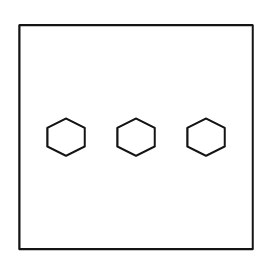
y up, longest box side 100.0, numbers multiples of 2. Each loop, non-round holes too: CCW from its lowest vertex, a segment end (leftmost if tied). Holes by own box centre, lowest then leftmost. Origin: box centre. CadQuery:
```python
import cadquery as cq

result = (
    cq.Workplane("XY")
    .moveTo(-50.0, -48.0)
    .lineTo(50.0, -48.0)
    .lineTo(50.0, 48.0)
    .lineTo(-50.0, 48.0)
    .close()
    .moveTo(-30.0, -8.0)
    .lineTo(-22.0, -4.0)
    .lineTo(-22.0, 4.0)
    .lineTo(-30.0, 8.0)
    .lineTo(-38.0, 4.0)
    .lineTo(-38.0, -4.0)
    .close()
    .moveTo(0.0, -8.0)
    .lineTo(8.0, -4.0)
    .lineTo(8.0, 4.0)
    .lineTo(0.0, 8.0)
    .lineTo(-8.0, 4.0)
    .lineTo(-8.0, -4.0)
    .close()
    .moveTo(30.0, -8.0)
    .lineTo(38.0, -4.0)
    .lineTo(38.0, 4.0)
    .lineTo(30.0, 8.0)
    .lineTo(22.0, 4.0)
    .lineTo(22.0, -4.0)
    .close()
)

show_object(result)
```